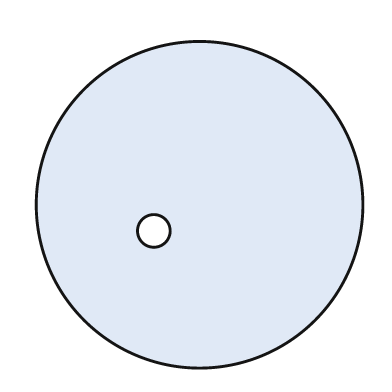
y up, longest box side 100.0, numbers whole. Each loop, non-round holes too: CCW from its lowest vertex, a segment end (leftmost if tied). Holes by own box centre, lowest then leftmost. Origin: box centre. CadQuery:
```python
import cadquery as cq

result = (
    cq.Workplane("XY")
    .moveTo(0.0, 0.0)
    .circle(50.0)
    .moveTo(-14.0, -8.0)
    .circle(5.0)
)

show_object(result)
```